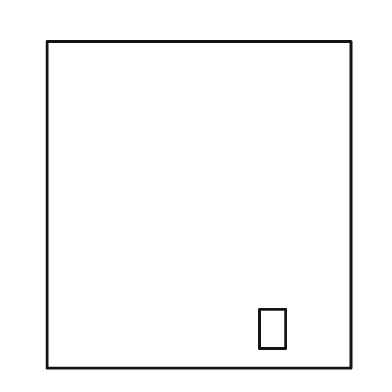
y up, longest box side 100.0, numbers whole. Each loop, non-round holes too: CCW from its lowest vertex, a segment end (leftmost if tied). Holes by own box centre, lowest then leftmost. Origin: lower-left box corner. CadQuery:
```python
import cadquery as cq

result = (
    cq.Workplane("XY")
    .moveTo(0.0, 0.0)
    .lineTo(93.0, 0.0)
    .lineTo(93.0, 100.0)
    .lineTo(0.0, 100.0)
    .close()
    .moveTo(65.0, 6.0)
    .lineTo(73.0, 6.0)
    .lineTo(73.0, 18.0)
    .lineTo(65.0, 18.0)
    .close()
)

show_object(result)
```